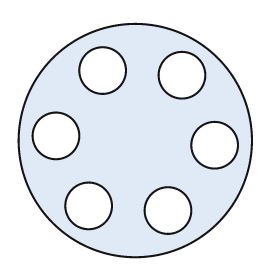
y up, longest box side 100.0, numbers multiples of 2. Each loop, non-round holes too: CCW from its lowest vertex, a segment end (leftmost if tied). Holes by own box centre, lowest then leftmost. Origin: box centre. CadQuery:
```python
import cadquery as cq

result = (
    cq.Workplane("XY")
    .moveTo(0.0, 0.0)
    .circle(50.0)
    .moveTo(14.0, -30.0)
    .circle(10.0)
    .moveTo(-20.0, -28.0)
    .circle(10.0)
    .moveTo(34.0, -2.0)
    .circle(10.0)
    .moveTo(-34.0, 2.0)
    .circle(10.0)
    .moveTo(20.0, 28.0)
    .circle(10.0)
    .moveTo(-14.0, 30.0)
    .circle(10.0)
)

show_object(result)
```